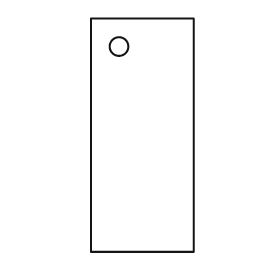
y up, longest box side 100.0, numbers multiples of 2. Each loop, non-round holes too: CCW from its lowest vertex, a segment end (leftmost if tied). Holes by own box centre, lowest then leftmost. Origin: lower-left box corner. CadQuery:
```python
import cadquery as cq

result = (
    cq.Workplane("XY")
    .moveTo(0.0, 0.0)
    .lineTo(44.0, 0.0)
    .lineTo(44.0, 100.0)
    .lineTo(0.0, 100.0)
    .close()
    .moveTo(12.0, 88.0)
    .circle(4.0)
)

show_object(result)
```